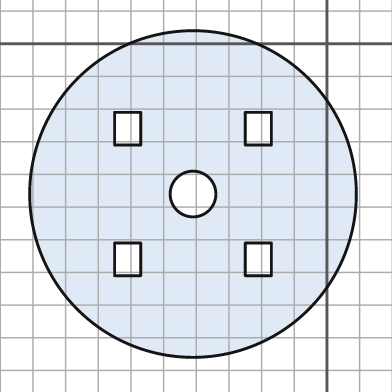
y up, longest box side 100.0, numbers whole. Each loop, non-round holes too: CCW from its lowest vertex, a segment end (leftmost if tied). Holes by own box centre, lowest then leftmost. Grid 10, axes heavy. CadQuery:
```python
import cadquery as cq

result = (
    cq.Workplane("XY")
    .moveTo(-41.0, -46.0)
    .circle(50.0)
    .moveTo(-65.0, -71.0)
    .lineTo(-57.0, -71.0)
    .lineTo(-57.0, -61.0)
    .lineTo(-65.0, -61.0)
    .close()
    .moveTo(-25.0, -71.0)
    .lineTo(-17.0, -71.0)
    .lineTo(-17.0, -61.0)
    .lineTo(-25.0, -61.0)
    .close()
    .moveTo(-41.0, -46.0)
    .circle(7.0)
    .moveTo(-65.0, -31.0)
    .lineTo(-57.0, -31.0)
    .lineTo(-57.0, -21.0)
    .lineTo(-65.0, -21.0)
    .close()
    .moveTo(-25.0, -31.0)
    .lineTo(-17.0, -31.0)
    .lineTo(-17.0, -21.0)
    .lineTo(-25.0, -21.0)
    .close()
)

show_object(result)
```